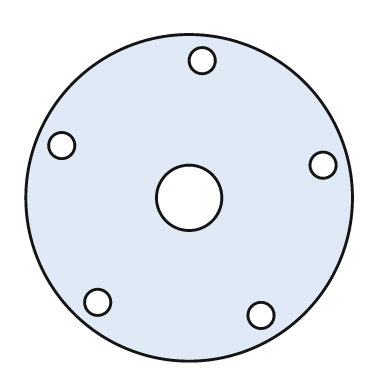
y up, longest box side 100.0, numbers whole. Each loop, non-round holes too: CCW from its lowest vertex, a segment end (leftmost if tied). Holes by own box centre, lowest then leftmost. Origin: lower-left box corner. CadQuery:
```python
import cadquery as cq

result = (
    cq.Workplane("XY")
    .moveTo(50.0, 50.0)
    .circle(50.0)
    .moveTo(72.0, 14.0)
    .circle(4.0)
    .moveTo(22.0, 18.0)
    .circle(4.0)
    .moveTo(50.0, 50.0)
    .circle(10.0)
    .moveTo(91.0, 60.0)
    .circle(4.0)
    .moveTo(11.0, 66.0)
    .circle(4.0)
    .moveTo(54.0, 92.0)
    .circle(4.0)
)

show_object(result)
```